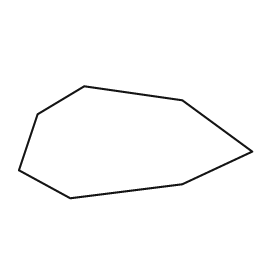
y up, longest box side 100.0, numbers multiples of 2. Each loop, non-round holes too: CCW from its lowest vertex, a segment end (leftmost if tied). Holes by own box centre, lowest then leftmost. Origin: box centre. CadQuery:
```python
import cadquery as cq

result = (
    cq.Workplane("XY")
    .moveTo(-28.0, -24.0)
    .lineTo(20.0, -18.0)
    .lineTo(50.0, -4.0)
    .lineTo(20.0, 18.0)
    .lineTo(-22.0, 24.0)
    .lineTo(-42.0, 12.0)
    .lineTo(-50.0, -12.0)
    .close()
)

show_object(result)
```